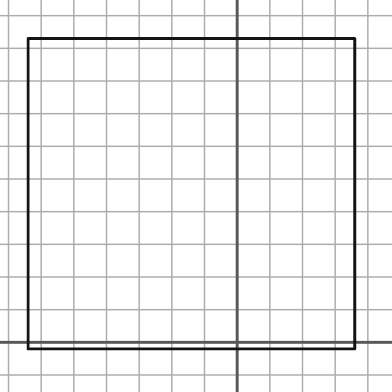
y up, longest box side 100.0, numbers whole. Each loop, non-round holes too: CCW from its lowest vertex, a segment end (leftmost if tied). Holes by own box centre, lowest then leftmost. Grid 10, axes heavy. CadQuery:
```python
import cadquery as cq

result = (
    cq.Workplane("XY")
    .moveTo(-64.0, -2.0)
    .lineTo(36.0, -2.0)
    .lineTo(36.0, 93.0)
    .lineTo(-64.0, 93.0)
    .close()
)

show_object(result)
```